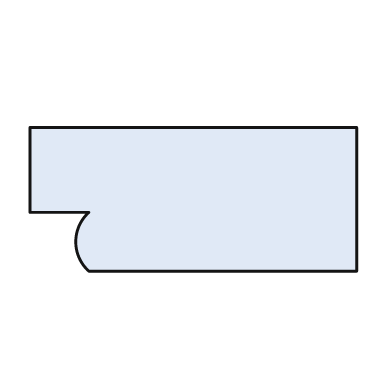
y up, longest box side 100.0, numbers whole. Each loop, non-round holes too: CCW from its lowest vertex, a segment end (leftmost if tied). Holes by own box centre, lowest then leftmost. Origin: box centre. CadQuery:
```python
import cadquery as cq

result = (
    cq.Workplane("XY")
    .moveTo(-32.0, -22.0)
    .lineTo(50.0, -22.0)
    .lineTo(50.0, 22.0)
    .lineTo(-50.0, 22.0)
    .lineTo(-50.0, -4.0)
    .lineTo(-32.0, -4.0)
    .threePointArc((-36.0, -13.0), (-32.0, -22.0))
    .close()
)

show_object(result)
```